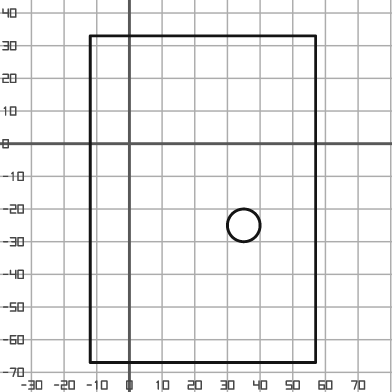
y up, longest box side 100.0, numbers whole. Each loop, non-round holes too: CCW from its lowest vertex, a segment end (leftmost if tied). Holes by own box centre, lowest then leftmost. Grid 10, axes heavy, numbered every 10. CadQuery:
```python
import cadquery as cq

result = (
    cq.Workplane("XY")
    .moveTo(-12.0, -67.0)
    .lineTo(57.0, -67.0)
    .lineTo(57.0, 33.0)
    .lineTo(-12.0, 33.0)
    .close()
    .moveTo(35.0, -25.0)
    .circle(5.0)
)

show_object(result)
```